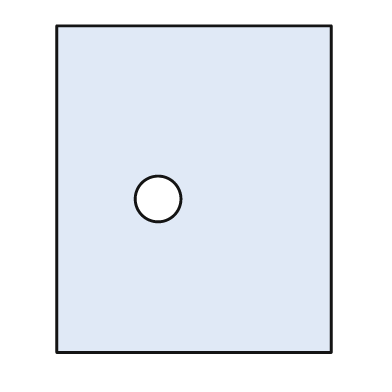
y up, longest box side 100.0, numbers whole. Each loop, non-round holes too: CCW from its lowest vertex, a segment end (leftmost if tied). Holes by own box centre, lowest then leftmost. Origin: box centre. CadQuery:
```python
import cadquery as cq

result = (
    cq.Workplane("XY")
    .moveTo(-42.0, -50.0)
    .lineTo(42.0, -50.0)
    .lineTo(42.0, 50.0)
    .lineTo(-42.0, 50.0)
    .close()
    .moveTo(-11.0, -3.0)
    .circle(7.0)
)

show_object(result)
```